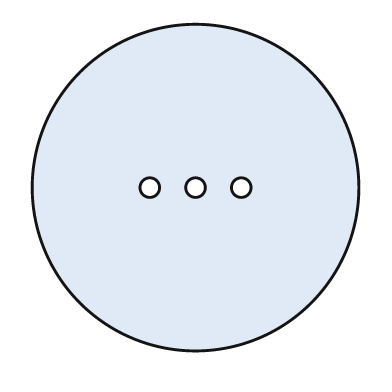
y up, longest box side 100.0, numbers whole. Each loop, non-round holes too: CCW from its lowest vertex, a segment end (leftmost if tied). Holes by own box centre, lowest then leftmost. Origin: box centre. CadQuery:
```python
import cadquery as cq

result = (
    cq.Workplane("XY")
    .moveTo(0.0, 0.0)
    .circle(50.0)
    .moveTo(-14.0, 0.0)
    .circle(3.0)
    .moveTo(0.0, 0.0)
    .circle(3.0)
    .moveTo(14.0, 0.0)
    .circle(3.0)
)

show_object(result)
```